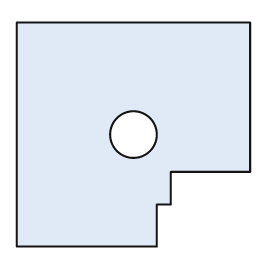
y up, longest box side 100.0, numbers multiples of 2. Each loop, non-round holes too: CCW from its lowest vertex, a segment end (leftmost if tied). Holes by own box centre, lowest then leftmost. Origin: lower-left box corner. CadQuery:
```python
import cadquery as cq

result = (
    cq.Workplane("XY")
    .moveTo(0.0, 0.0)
    .lineTo(60.0, 0.0)
    .lineTo(60.0, 18.0)
    .lineTo(66.0, 18.0)
    .lineTo(66.0, 32.0)
    .lineTo(100.0, 32.0)
    .lineTo(100.0, 96.0)
    .lineTo(0.0, 96.0)
    .close()
    .moveTo(50.0, 48.0)
    .circle(10.0)
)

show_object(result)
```